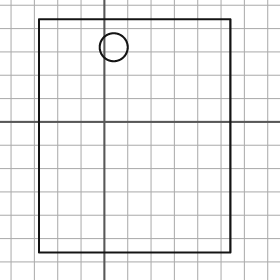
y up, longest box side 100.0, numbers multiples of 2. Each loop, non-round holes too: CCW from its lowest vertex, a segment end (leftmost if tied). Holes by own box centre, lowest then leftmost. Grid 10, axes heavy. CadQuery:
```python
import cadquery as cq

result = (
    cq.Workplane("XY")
    .moveTo(-28.0, -56.0)
    .lineTo(54.0, -56.0)
    .lineTo(54.0, 44.0)
    .lineTo(-28.0, 44.0)
    .close()
    .moveTo(4.0, 32.0)
    .circle(6.0)
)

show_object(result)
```